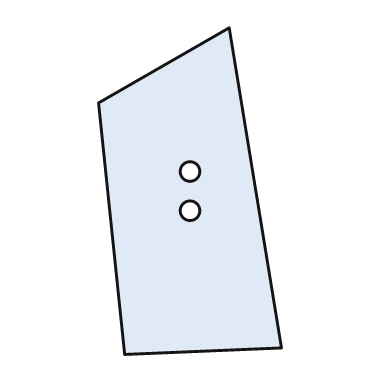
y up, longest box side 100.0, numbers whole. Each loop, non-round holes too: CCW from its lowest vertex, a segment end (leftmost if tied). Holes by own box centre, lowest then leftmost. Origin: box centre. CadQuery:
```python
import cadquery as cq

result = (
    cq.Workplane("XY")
    .moveTo(-20.0, -50.0)
    .lineTo(28.0, -48.0)
    .lineTo(12.0, 50.0)
    .lineTo(-28.0, 27.0)
    .close()
    .moveTo(0.0, -6.0)
    .circle(3.0)
    .moveTo(0.0, 6.0)
    .circle(3.0)
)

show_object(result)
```